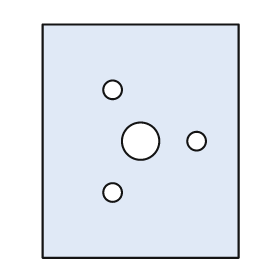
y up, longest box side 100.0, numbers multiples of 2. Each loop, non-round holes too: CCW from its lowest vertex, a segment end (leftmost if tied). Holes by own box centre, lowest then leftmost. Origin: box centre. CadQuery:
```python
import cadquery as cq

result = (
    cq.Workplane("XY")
    .moveTo(-42.0, -50.0)
    .lineTo(42.0, -50.0)
    .lineTo(42.0, 50.0)
    .lineTo(-42.0, 50.0)
    .close()
    .moveTo(-12.0, -22.0)
    .circle(4.0)
    .moveTo(0.0, 0.0)
    .circle(8.0)
    .moveTo(24.0, 0.0)
    .circle(4.0)
    .moveTo(-12.0, 22.0)
    .circle(4.0)
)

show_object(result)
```